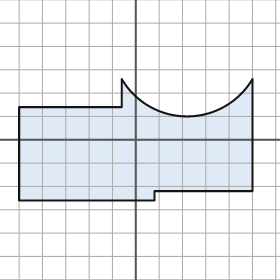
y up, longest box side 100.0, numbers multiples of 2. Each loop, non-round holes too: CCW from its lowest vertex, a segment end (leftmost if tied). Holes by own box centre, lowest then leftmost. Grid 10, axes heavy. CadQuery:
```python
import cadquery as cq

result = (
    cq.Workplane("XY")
    .moveTo(-50.0, -26.0)
    .lineTo(8.0, -26.0)
    .lineTo(8.0, -22.0)
    .lineTo(50.0, -22.0)
    .lineTo(50.0, 26.0)
    .threePointArc((22.0, 10.0), (-6.0, 26.0))
    .lineTo(-6.0, 14.0)
    .lineTo(-50.0, 14.0)
    .close()
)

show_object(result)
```